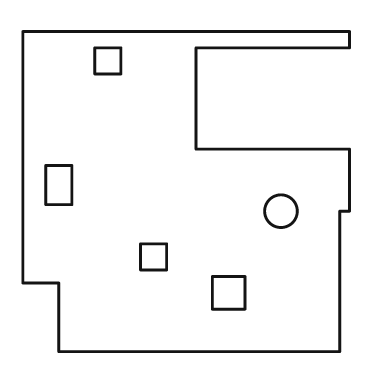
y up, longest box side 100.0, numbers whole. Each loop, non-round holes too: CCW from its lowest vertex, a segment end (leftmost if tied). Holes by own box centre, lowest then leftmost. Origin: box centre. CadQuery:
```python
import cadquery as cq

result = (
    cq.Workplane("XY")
    .moveTo(-39.0, -49.0)
    .lineTo(47.0, -49.0)
    .lineTo(47.0, -6.0)
    .lineTo(50.0, -6.0)
    .lineTo(50.0, 13.0)
    .lineTo(3.0, 13.0)
    .lineTo(3.0, 44.0)
    .lineTo(50.0, 44.0)
    .lineTo(50.0, 49.0)
    .lineTo(-50.0, 49.0)
    .lineTo(-50.0, -28.0)
    .lineTo(-39.0, -28.0)
    .close()
    .moveTo(8.0, -36.0)
    .lineTo(18.0, -36.0)
    .lineTo(18.0, -26.0)
    .lineTo(8.0, -26.0)
    .close()
    .moveTo(-14.0, -24.0)
    .lineTo(-6.0, -24.0)
    .lineTo(-6.0, -16.0)
    .lineTo(-14.0, -16.0)
    .close()
    .moveTo(29.0, -6.0)
    .circle(5.0)
    .moveTo(-43.0, -4.0)
    .lineTo(-35.0, -4.0)
    .lineTo(-35.0, 8.0)
    .lineTo(-43.0, 8.0)
    .close()
    .moveTo(-28.0, 36.0)
    .lineTo(-20.0, 36.0)
    .lineTo(-20.0, 44.0)
    .lineTo(-28.0, 44.0)
    .close()
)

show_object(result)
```